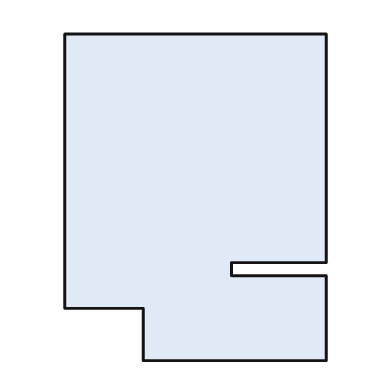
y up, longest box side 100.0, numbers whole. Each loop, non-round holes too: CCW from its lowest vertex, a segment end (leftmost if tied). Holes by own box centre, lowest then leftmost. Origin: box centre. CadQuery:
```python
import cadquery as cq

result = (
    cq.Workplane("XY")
    .moveTo(-16.0, -50.0)
    .lineTo(40.0, -50.0)
    .lineTo(40.0, -24.0)
    .lineTo(11.0, -24.0)
    .lineTo(11.0, -20.0)
    .lineTo(40.0, -20.0)
    .lineTo(40.0, 50.0)
    .lineTo(-40.0, 50.0)
    .lineTo(-40.0, -34.0)
    .lineTo(-16.0, -34.0)
    .close()
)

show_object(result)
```